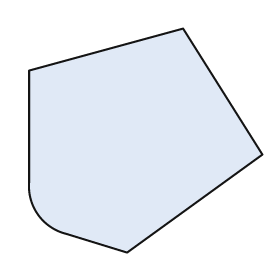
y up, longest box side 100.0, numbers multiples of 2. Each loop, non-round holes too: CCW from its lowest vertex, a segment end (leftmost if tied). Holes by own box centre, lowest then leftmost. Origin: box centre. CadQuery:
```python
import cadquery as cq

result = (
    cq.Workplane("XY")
    .moveTo(-8.0, -48.0)
    .lineTo(50.0, -6.0)
    .lineTo(16.0, 48.0)
    .lineTo(-50.0, 30.0)
    .lineTo(-50.0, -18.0)
    .threePointArc((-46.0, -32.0), (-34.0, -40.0))
    .close()
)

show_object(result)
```